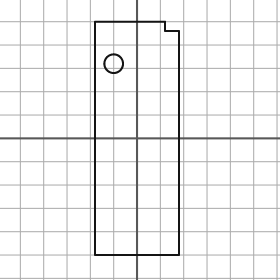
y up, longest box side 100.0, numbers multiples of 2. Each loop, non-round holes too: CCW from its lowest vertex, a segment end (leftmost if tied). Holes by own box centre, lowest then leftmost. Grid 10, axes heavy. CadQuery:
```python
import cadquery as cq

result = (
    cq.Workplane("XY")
    .moveTo(-18.0, -50.0)
    .lineTo(18.0, -50.0)
    .lineTo(18.0, 46.0)
    .lineTo(12.0, 46.0)
    .lineTo(12.0, 50.0)
    .lineTo(-18.0, 50.0)
    .close()
    .moveTo(-10.0, 32.0)
    .circle(4.0)
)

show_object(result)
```